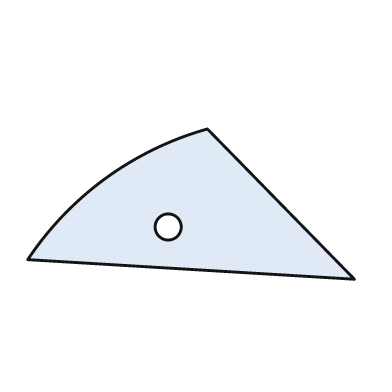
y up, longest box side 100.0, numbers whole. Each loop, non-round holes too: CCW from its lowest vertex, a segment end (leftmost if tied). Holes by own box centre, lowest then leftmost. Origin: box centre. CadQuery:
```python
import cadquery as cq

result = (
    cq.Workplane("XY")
    .moveTo(50.0, -23.0)
    .lineTo(5.0, 23.0)
    .threePointArc((-26.0, 8.0), (-50.0, -17.0))
    .close()
    .moveTo(-7.0, -7.0)
    .circle(4.0)
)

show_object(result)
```